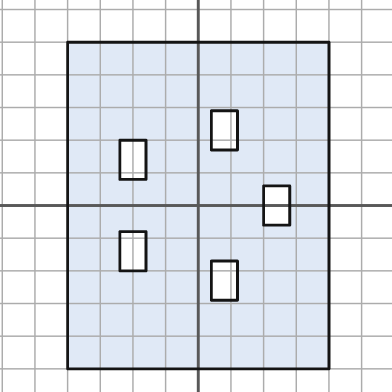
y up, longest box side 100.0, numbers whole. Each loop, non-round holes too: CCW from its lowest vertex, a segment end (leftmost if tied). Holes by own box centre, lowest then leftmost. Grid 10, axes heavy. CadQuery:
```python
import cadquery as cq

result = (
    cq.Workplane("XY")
    .moveTo(-40.0, -50.0)
    .lineTo(40.0, -50.0)
    .lineTo(40.0, 50.0)
    .lineTo(-40.0, 50.0)
    .close()
    .moveTo(4.0, -29.0)
    .lineTo(12.0, -29.0)
    .lineTo(12.0, -17.0)
    .lineTo(4.0, -17.0)
    .close()
    .moveTo(-24.0, -20.0)
    .lineTo(-16.0, -20.0)
    .lineTo(-16.0, -8.0)
    .lineTo(-24.0, -8.0)
    .close()
    .moveTo(20.0, -6.0)
    .lineTo(28.0, -6.0)
    .lineTo(28.0, 6.0)
    .lineTo(20.0, 6.0)
    .close()
    .moveTo(-24.0, 8.0)
    .lineTo(-16.0, 8.0)
    .lineTo(-16.0, 20.0)
    .lineTo(-24.0, 20.0)
    .close()
    .moveTo(4.0, 17.0)
    .lineTo(12.0, 17.0)
    .lineTo(12.0, 29.0)
    .lineTo(4.0, 29.0)
    .close()
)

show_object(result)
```